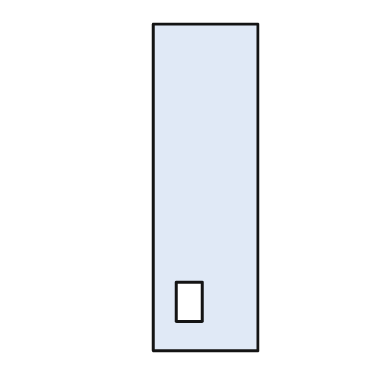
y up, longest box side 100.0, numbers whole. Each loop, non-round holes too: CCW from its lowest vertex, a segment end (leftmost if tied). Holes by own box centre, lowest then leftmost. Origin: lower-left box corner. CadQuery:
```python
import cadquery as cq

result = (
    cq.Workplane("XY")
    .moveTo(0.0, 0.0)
    .lineTo(32.0, 0.0)
    .lineTo(32.0, 100.0)
    .lineTo(0.0, 100.0)
    .close()
    .moveTo(7.0, 9.0)
    .lineTo(15.0, 9.0)
    .lineTo(15.0, 21.0)
    .lineTo(7.0, 21.0)
    .close()
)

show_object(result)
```